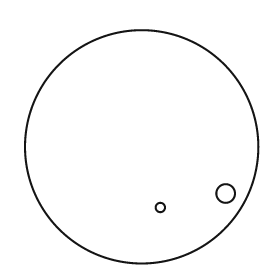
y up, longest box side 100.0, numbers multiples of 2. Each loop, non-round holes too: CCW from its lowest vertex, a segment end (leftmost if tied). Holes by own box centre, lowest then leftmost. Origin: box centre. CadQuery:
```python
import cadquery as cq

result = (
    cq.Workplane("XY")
    .moveTo(0.0, 0.0)
    .circle(50.0)
    .moveTo(8.0, -26.0)
    .circle(2.0)
    .moveTo(36.0, -20.0)
    .circle(4.0)
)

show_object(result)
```